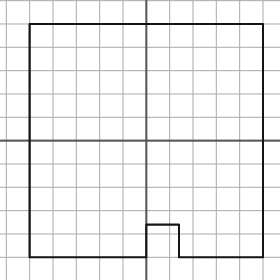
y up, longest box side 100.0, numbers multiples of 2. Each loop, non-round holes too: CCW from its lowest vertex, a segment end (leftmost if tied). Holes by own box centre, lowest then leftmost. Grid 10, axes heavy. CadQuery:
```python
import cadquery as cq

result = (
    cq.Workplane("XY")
    .moveTo(-50.0, -50.0)
    .lineTo(0.0, -50.0)
    .lineTo(0.0, -36.0)
    .lineTo(14.0, -36.0)
    .lineTo(14.0, -50.0)
    .lineTo(50.0, -50.0)
    .lineTo(50.0, 50.0)
    .lineTo(-50.0, 50.0)
    .close()
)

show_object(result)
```